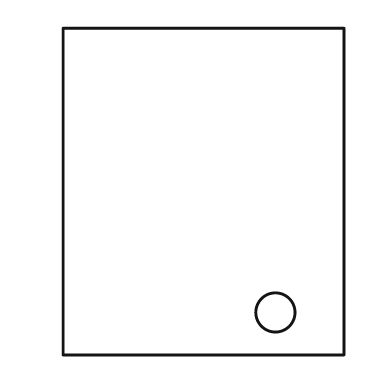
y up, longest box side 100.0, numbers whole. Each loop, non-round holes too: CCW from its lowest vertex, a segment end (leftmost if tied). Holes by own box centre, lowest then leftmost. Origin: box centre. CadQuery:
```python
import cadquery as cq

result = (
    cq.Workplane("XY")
    .moveTo(-43.0, -50.0)
    .lineTo(43.0, -50.0)
    .lineTo(43.0, 50.0)
    .lineTo(-43.0, 50.0)
    .close()
    .moveTo(22.0, -37.0)
    .circle(6.0)
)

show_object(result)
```